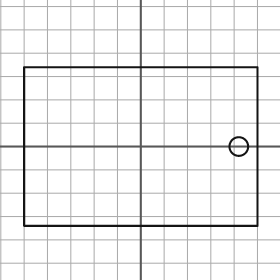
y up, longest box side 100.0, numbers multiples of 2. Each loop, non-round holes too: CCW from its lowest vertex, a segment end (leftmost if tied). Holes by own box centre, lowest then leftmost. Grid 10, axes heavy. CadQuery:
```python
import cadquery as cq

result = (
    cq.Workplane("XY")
    .moveTo(-50.0, -34.0)
    .lineTo(50.0, -34.0)
    .lineTo(50.0, 34.0)
    .lineTo(-50.0, 34.0)
    .close()
    .moveTo(42.0, 0.0)
    .circle(4.0)
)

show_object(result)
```